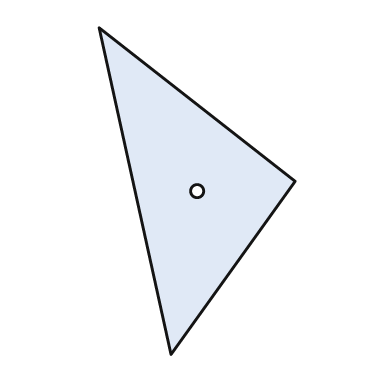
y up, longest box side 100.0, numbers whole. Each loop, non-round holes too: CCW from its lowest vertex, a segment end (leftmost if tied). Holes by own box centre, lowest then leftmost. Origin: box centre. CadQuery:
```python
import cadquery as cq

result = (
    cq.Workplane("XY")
    .moveTo(-8.0, -50.0)
    .lineTo(30.0, 3.0)
    .lineTo(-30.0, 50.0)
    .close()
    .moveTo(0.0, 0.0)
    .circle(2.0)
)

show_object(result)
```